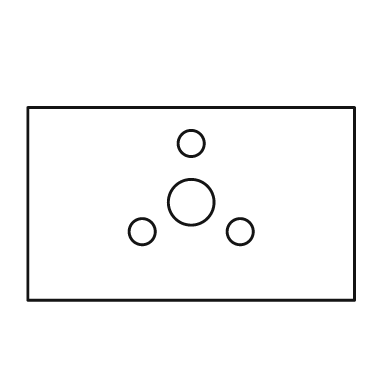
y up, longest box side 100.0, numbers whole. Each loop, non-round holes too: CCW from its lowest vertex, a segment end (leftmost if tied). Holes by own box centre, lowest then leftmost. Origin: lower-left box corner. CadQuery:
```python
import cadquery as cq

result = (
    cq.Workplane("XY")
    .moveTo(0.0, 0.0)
    .lineTo(100.0, 0.0)
    .lineTo(100.0, 59.0)
    .lineTo(0.0, 59.0)
    .close()
    .moveTo(35.0, 21.0)
    .circle(4.0)
    .moveTo(65.0, 21.0)
    .circle(4.0)
    .moveTo(50.0, 30.0)
    .circle(7.0)
    .moveTo(50.0, 48.0)
    .circle(4.0)
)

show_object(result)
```